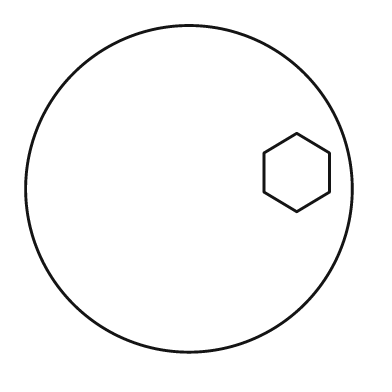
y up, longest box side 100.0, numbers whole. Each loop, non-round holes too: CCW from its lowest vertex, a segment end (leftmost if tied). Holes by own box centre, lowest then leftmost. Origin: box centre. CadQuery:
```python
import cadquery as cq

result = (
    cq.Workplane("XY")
    .moveTo(0.0, 0.0)
    .circle(50.0)
    .moveTo(33.0, -7.0)
    .lineTo(43.0, -1.0)
    .lineTo(43.0, 11.0)
    .lineTo(33.0, 17.0)
    .lineTo(23.0, 11.0)
    .lineTo(23.0, -1.0)
    .close()
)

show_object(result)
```